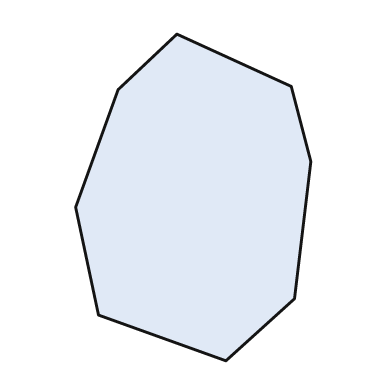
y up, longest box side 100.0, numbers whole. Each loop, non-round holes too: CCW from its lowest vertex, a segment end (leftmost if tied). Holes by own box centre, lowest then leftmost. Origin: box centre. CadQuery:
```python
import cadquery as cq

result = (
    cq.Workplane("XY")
    .moveTo(10.0, -50.0)
    .lineTo(31.0, -31.0)
    .lineTo(36.0, 11.0)
    .lineTo(30.0, 34.0)
    .lineTo(-5.0, 50.0)
    .lineTo(-23.0, 33.0)
    .lineTo(-36.0, -3.0)
    .lineTo(-29.0, -36.0)
    .close()
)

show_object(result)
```